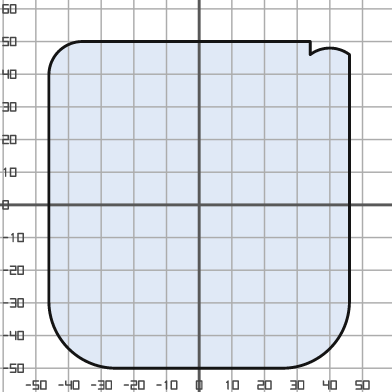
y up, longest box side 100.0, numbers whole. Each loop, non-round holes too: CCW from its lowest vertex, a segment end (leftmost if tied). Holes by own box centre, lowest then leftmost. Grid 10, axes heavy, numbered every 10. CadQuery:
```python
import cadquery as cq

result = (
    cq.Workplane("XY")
    .moveTo(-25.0, -50.0)
    .lineTo(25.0, -50.0)
    .threePointArc((40.0, -44.0), (46.0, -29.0))
    .lineTo(46.0, 46.0)
    .threePointArc((40.0, 48.0), (34.0, 46.0))
    .lineTo(34.0, 50.0)
    .lineTo(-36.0, 50.0)
    .threePointArc((-43.0, 47.0), (-46.0, 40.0))
    .lineTo(-46.0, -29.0)
    .threePointArc((-40.0, -44.0), (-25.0, -50.0))
    .close()
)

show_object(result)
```